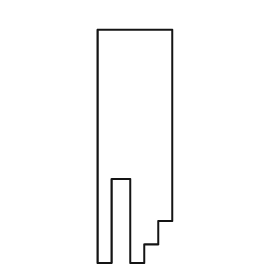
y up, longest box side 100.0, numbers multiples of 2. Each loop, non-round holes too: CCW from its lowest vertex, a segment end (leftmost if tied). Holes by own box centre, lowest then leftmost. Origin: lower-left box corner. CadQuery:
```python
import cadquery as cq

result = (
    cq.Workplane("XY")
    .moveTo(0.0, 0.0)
    .lineTo(6.0, 0.0)
    .lineTo(6.0, 36.0)
    .lineTo(14.0, 36.0)
    .lineTo(14.0, 0.0)
    .lineTo(20.0, 0.0)
    .lineTo(20.0, 8.0)
    .lineTo(26.0, 8.0)
    .lineTo(26.0, 18.0)
    .lineTo(32.0, 18.0)
    .lineTo(32.0, 100.0)
    .lineTo(0.0, 100.0)
    .close()
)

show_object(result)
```